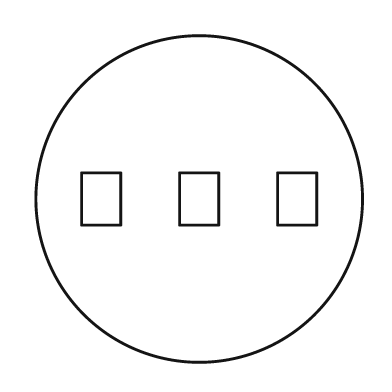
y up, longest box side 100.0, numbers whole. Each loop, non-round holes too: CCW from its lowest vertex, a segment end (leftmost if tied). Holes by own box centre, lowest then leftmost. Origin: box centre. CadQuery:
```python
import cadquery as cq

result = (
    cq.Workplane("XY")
    .moveTo(0.0, 0.0)
    .circle(50.0)
    .moveTo(-36.0, -8.0)
    .lineTo(-24.0, -8.0)
    .lineTo(-24.0, 8.0)
    .lineTo(-36.0, 8.0)
    .close()
    .moveTo(-6.0, -8.0)
    .lineTo(6.0, -8.0)
    .lineTo(6.0, 8.0)
    .lineTo(-6.0, 8.0)
    .close()
    .moveTo(24.0, -8.0)
    .lineTo(36.0, -8.0)
    .lineTo(36.0, 8.0)
    .lineTo(24.0, 8.0)
    .close()
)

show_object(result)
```